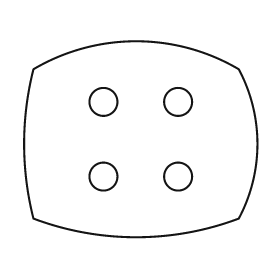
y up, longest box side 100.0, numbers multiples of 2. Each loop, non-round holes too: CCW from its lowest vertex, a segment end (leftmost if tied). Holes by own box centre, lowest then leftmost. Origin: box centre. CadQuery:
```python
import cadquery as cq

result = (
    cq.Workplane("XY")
    .moveTo(-46.0, -34.0)
    .threePointArc((-2.0, -42.0), (42.0, -34.0))
    .threePointArc((50.0, -2.0), (42.0, 30.0))
    .threePointArc((-2.0, 42.0), (-46.0, 30.0))
    .threePointArc((-50.0, -2.0), (-46.0, -34.0))
    .close()
    .moveTo(-16.0, -16.0)
    .circle(6.0)
    .moveTo(16.0, -16.0)
    .circle(6.0)
    .moveTo(-16.0, 16.0)
    .circle(6.0)
    .moveTo(16.0, 16.0)
    .circle(6.0)
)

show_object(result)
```